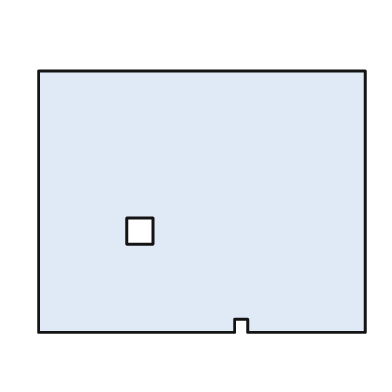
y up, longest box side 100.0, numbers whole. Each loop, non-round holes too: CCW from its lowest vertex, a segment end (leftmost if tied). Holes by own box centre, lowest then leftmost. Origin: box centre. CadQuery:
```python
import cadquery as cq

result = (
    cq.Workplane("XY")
    .moveTo(-50.0, -40.0)
    .lineTo(10.0, -40.0)
    .lineTo(10.0, -36.0)
    .lineTo(14.0, -36.0)
    .lineTo(14.0, -40.0)
    .lineTo(50.0, -40.0)
    .lineTo(50.0, 40.0)
    .lineTo(-50.0, 40.0)
    .close()
    .moveTo(-23.0, -13.0)
    .lineTo(-15.0, -13.0)
    .lineTo(-15.0, -5.0)
    .lineTo(-23.0, -5.0)
    .close()
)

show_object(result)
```